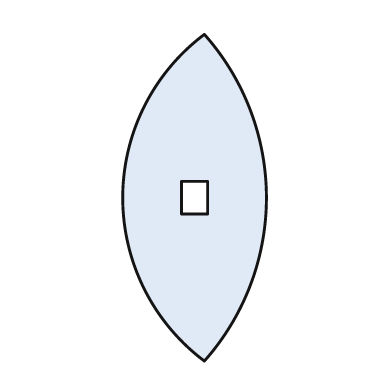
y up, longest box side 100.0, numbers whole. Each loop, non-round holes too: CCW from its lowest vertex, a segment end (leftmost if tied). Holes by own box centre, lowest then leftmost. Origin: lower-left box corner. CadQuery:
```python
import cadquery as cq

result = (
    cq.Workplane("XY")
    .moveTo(25.0, 0.0)
    .threePointArc((44.0, 50.0), (25.0, 100.0))
    .threePointArc((0.0, 50.0), (25.0, 0.0))
    .close()
    .moveTo(18.0, 45.0)
    .lineTo(26.0, 45.0)
    .lineTo(26.0, 55.0)
    .lineTo(18.0, 55.0)
    .close()
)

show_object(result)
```